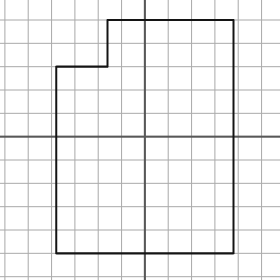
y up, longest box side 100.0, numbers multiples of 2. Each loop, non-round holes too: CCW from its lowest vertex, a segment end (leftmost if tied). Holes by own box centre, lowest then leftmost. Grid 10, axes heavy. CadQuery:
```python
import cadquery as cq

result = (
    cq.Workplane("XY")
    .moveTo(-38.0, -50.0)
    .lineTo(38.0, -50.0)
    .lineTo(38.0, 50.0)
    .lineTo(-16.0, 50.0)
    .lineTo(-16.0, 30.0)
    .lineTo(-38.0, 30.0)
    .close()
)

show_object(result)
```